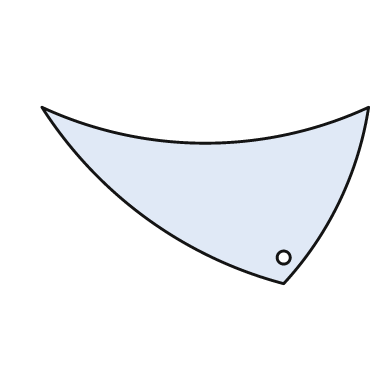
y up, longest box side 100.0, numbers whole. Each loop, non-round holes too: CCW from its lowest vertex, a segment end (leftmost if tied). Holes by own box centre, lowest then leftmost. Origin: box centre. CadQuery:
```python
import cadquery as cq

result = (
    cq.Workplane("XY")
    .moveTo(24.0, -27.0)
    .threePointArc((41.0, -2.0), (50.0, 27.0))
    .threePointArc((0.0, 16.0), (-50.0, 27.0))
    .threePointArc((-18.0, -7.0), (24.0, -27.0))
    .close()
    .moveTo(24.0, -19.0)
    .circle(2.0)
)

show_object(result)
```